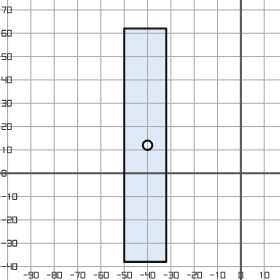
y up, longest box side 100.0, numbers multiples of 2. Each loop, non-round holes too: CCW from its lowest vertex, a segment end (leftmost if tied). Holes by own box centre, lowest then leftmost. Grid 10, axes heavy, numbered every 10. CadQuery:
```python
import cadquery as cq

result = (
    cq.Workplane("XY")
    .moveTo(-50.0, -38.0)
    .lineTo(-32.0, -38.0)
    .lineTo(-32.0, 62.0)
    .lineTo(-50.0, 62.0)
    .close()
    .moveTo(-40.0, 12.0)
    .circle(2.0)
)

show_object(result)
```